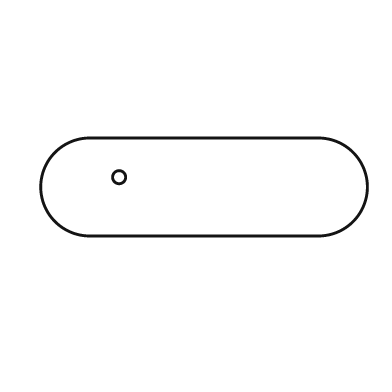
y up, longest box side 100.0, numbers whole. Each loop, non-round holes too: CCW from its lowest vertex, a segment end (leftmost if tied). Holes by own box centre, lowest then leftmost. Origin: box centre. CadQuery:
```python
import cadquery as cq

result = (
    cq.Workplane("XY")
    .moveTo(-35.0, -15.0)
    .lineTo(35.0, -15.0)
    .threePointArc((50.0, 0.0), (35.0, 15.0))
    .lineTo(-35.0, 15.0)
    .threePointArc((-50.0, 0.0), (-35.0, -15.0))
    .close()
    .moveTo(-26.0, 3.0)
    .circle(2.0)
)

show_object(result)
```